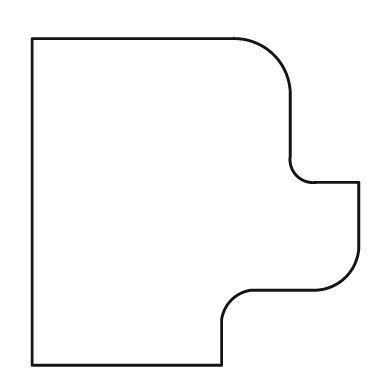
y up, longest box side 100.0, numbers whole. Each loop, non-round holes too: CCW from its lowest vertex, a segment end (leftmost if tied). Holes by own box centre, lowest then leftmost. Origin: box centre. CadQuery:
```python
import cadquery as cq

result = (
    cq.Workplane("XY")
    .moveTo(-50.0, -50.0)
    .lineTo(8.0, -50.0)
    .lineTo(8.0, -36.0)
    .threePointArc((11.0, -30.0), (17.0, -27.0))
    .lineTo(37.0, -27.0)
    .threePointArc((46.0, -23.0), (50.0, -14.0))
    .lineTo(50.0, 6.0)
    .lineTo(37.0, 6.0)
    .threePointArc((31.0, 8.0), (29.0, 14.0))
    .lineTo(29.0, 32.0)
    .threePointArc((24.0, 45.0), (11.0, 50.0))
    .lineTo(-50.0, 50.0)
    .close()
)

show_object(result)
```